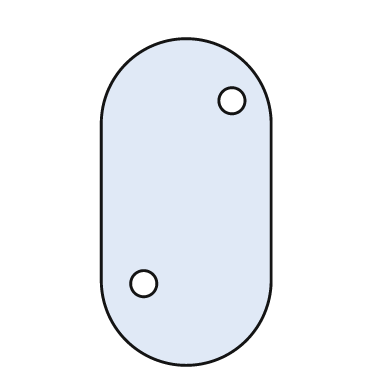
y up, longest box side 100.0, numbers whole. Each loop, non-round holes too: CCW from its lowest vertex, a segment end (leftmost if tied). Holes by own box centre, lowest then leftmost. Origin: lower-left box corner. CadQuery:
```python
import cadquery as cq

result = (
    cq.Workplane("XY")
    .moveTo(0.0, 26.0)
    .threePointArc((26.0, 0.0), (52.0, 26.0))
    .lineTo(52.0, 74.0)
    .threePointArc((26.0, 100.0), (0.0, 74.0))
    .close()
    .moveTo(13.0, 25.0)
    .circle(4.0)
    .moveTo(40.0, 81.0)
    .circle(4.0)
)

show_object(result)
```